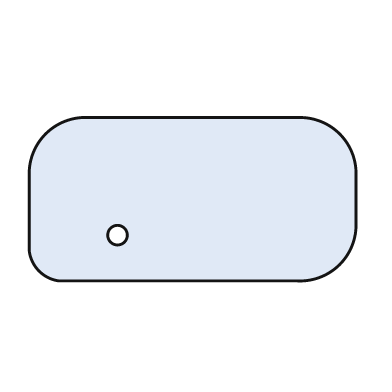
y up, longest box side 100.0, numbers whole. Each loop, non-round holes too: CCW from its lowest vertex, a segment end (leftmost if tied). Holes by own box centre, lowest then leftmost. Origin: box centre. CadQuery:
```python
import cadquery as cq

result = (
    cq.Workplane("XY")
    .moveTo(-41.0, -25.0)
    .lineTo(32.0, -25.0)
    .threePointArc((45.0, -20.0), (50.0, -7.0))
    .lineTo(50.0, 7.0)
    .threePointArc((45.0, 20.0), (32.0, 25.0))
    .lineTo(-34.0, 25.0)
    .threePointArc((-45.0, 20.0), (-50.0, 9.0))
    .lineTo(-50.0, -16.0)
    .threePointArc((-47.0, -22.0), (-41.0, -25.0))
    .close()
    .moveTo(-23.0, -11.0)
    .circle(3.0)
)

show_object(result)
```